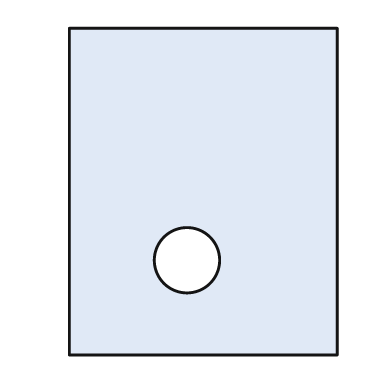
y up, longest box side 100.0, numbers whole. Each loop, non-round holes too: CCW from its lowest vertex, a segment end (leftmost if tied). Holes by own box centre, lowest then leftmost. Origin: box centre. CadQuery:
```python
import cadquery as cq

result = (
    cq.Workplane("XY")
    .moveTo(-41.0, -50.0)
    .lineTo(41.0, -50.0)
    .lineTo(41.0, 50.0)
    .lineTo(-41.0, 50.0)
    .close()
    .moveTo(-5.0, -21.0)
    .circle(10.0)
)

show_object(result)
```